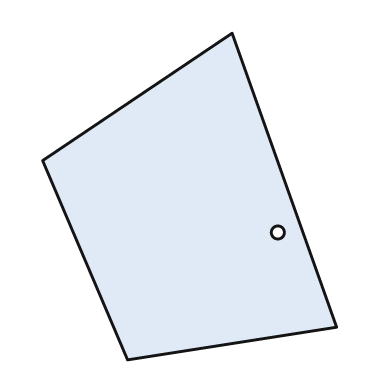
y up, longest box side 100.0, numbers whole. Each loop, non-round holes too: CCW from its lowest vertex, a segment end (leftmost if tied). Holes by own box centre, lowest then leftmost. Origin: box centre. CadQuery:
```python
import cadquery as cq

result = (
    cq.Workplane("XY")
    .moveTo(-19.0, -50.0)
    .lineTo(45.0, -40.0)
    .lineTo(13.0, 50.0)
    .lineTo(-45.0, 11.0)
    .close()
    .moveTo(27.0, -11.0)
    .circle(2.0)
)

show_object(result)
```